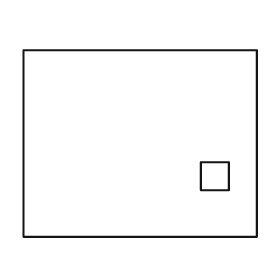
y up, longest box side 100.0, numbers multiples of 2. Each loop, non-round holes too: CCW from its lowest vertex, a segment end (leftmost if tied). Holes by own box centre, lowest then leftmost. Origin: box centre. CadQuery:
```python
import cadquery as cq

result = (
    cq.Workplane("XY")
    .moveTo(-50.0, -40.0)
    .lineTo(50.0, -40.0)
    .lineTo(50.0, 40.0)
    .lineTo(-50.0, 40.0)
    .close()
    .moveTo(26.0, -20.0)
    .lineTo(38.0, -20.0)
    .lineTo(38.0, -8.0)
    .lineTo(26.0, -8.0)
    .close()
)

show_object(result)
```